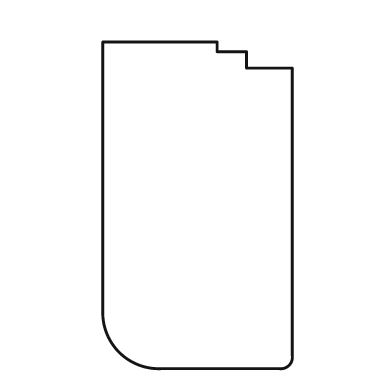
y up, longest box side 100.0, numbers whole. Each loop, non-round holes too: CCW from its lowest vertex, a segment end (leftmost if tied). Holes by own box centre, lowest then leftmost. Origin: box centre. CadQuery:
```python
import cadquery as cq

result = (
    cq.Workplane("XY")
    .moveTo(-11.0, -50.0)
    .lineTo(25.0, -50.0)
    .threePointArc((28.0, -49.0), (29.0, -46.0))
    .lineTo(29.0, 42.0)
    .lineTo(15.0, 42.0)
    .lineTo(15.0, 47.0)
    .lineTo(6.0, 47.0)
    .lineTo(6.0, 50.0)
    .lineTo(-29.0, 50.0)
    .lineTo(-29.0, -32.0)
    .threePointArc((-24.0, -45.0), (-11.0, -50.0))
    .close()
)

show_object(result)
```